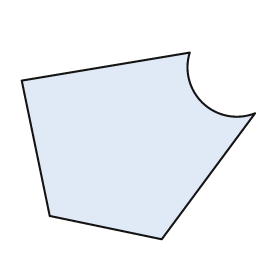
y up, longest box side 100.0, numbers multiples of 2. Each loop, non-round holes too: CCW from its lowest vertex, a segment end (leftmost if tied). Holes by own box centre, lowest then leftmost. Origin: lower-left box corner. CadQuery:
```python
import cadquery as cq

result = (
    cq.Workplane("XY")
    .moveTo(60.0, 0.0)
    .lineTo(100.0, 54.0)
    .threePointArc((78.0, 58.0), (72.0, 80.0))
    .lineTo(0.0, 68.0)
    .lineTo(12.0, 10.0)
    .close()
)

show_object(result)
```